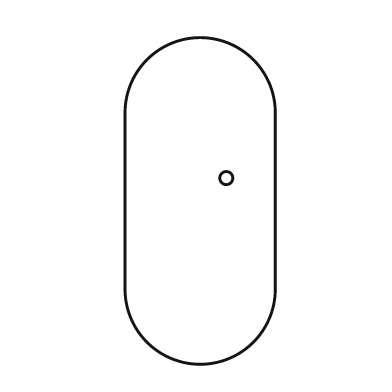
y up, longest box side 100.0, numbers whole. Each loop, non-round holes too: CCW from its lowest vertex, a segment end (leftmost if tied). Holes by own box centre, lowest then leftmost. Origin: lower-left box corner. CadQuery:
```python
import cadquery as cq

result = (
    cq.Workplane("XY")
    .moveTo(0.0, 23.0)
    .threePointArc((23.0, 0.0), (46.0, 23.0))
    .lineTo(46.0, 77.0)
    .threePointArc((23.0, 100.0), (0.0, 77.0))
    .close()
    .moveTo(31.0, 57.0)
    .circle(2.0)
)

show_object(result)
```